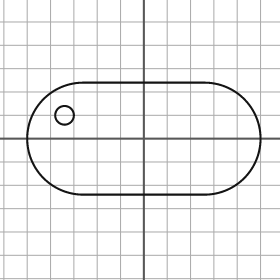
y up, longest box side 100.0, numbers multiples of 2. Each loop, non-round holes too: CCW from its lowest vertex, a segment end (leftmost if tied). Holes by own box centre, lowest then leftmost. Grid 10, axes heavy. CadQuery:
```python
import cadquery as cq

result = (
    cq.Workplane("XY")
    .moveTo(-26.0, -24.0)
    .lineTo(26.0, -24.0)
    .threePointArc((50.0, 0.0), (26.0, 24.0))
    .lineTo(-26.0, 24.0)
    .threePointArc((-50.0, 0.0), (-26.0, -24.0))
    .close()
    .moveTo(-34.0, 10.0)
    .circle(4.0)
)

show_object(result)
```